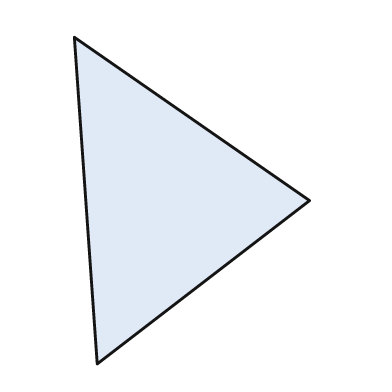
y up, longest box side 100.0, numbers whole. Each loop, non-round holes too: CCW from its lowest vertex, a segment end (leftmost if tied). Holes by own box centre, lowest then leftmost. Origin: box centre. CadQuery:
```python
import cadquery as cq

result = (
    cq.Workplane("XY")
    .moveTo(-29.0, -50.0)
    .lineTo(36.0, 0.0)
    .lineTo(-36.0, 50.0)
    .close()
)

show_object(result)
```